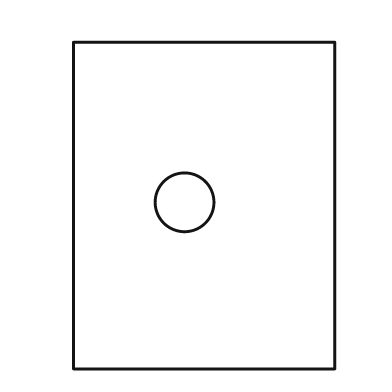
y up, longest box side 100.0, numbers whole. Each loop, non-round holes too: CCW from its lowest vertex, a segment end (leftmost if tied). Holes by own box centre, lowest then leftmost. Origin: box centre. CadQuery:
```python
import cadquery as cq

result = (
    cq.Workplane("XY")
    .moveTo(-40.0, -50.0)
    .lineTo(40.0, -50.0)
    .lineTo(40.0, 50.0)
    .lineTo(-40.0, 50.0)
    .close()
    .moveTo(-6.0, 1.0)
    .circle(9.0)
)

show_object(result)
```